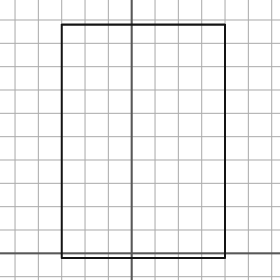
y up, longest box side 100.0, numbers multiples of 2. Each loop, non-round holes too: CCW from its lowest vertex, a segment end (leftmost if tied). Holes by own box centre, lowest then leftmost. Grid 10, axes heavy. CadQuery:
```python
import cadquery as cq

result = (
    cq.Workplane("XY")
    .moveTo(-30.0, -2.0)
    .lineTo(40.0, -2.0)
    .lineTo(40.0, 98.0)
    .lineTo(-30.0, 98.0)
    .close()
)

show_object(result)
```